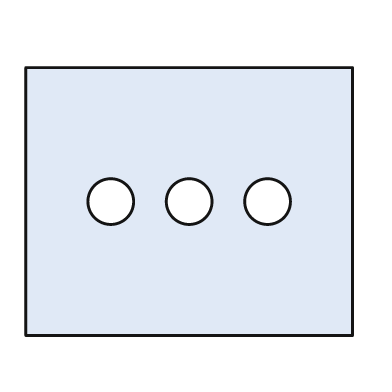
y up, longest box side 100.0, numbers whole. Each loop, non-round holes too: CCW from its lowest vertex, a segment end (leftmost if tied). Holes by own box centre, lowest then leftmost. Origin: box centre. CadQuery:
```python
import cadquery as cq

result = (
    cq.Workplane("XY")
    .moveTo(-50.0, -41.0)
    .lineTo(50.0, -41.0)
    .lineTo(50.0, 41.0)
    .lineTo(-50.0, 41.0)
    .close()
    .moveTo(-24.0, 0.0)
    .circle(7.0)
    .moveTo(0.0, 0.0)
    .circle(7.0)
    .moveTo(24.0, 0.0)
    .circle(7.0)
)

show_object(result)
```